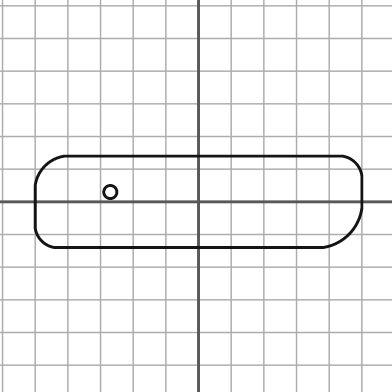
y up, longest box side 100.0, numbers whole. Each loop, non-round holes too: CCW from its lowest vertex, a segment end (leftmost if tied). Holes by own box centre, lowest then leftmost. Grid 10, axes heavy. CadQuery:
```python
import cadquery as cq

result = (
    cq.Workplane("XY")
    .moveTo(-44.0, -14.0)
    .lineTo(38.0, -14.0)
    .threePointArc((46.0, -10.0), (50.0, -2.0))
    .lineTo(50.0, 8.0)
    .threePointArc((48.0, 12.0), (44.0, 14.0))
    .lineTo(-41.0, 14.0)
    .threePointArc((-47.0, 11.0), (-50.0, 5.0))
    .lineTo(-50.0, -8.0)
    .threePointArc((-48.0, -12.0), (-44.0, -14.0))
    .close()
    .moveTo(-27.0, 3.0)
    .circle(2.0)
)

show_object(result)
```